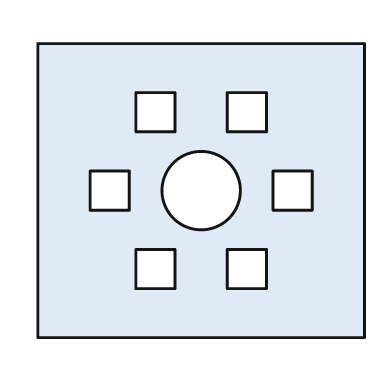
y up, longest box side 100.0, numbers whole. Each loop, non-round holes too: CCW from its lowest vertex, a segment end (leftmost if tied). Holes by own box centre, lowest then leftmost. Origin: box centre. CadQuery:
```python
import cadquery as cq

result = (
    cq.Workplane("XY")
    .moveTo(-50.0, -45.0)
    .lineTo(50.0, -45.0)
    .lineTo(50.0, 45.0)
    .lineTo(-50.0, 45.0)
    .close()
    .moveTo(-20.0, -30.0)
    .lineTo(-8.0, -30.0)
    .lineTo(-8.0, -18.0)
    .lineTo(-20.0, -18.0)
    .close()
    .moveTo(8.0, -30.0)
    .lineTo(20.0, -30.0)
    .lineTo(20.0, -18.0)
    .lineTo(8.0, -18.0)
    .close()
    .moveTo(-34.0, -6.0)
    .lineTo(-22.0, -6.0)
    .lineTo(-22.0, 6.0)
    .lineTo(-34.0, 6.0)
    .close()
    .moveTo(0.0, 0.0)
    .circle(12.0)
    .moveTo(22.0, -6.0)
    .lineTo(34.0, -6.0)
    .lineTo(34.0, 6.0)
    .lineTo(22.0, 6.0)
    .close()
    .moveTo(-20.0, 18.0)
    .lineTo(-8.0, 18.0)
    .lineTo(-8.0, 30.0)
    .lineTo(-20.0, 30.0)
    .close()
    .moveTo(8.0, 18.0)
    .lineTo(20.0, 18.0)
    .lineTo(20.0, 30.0)
    .lineTo(8.0, 30.0)
    .close()
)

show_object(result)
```